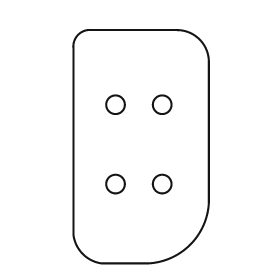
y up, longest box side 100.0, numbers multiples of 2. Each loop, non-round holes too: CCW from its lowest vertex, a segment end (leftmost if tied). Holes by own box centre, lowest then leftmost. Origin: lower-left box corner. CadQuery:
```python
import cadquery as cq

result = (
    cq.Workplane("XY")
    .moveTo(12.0, 0.0)
    .lineTo(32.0, 0.0)
    .threePointArc((50.0, 8.0), (58.0, 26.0))
    .lineTo(58.0, 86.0)
    .threePointArc((54.0, 96.0), (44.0, 100.0))
    .lineTo(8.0, 100.0)
    .threePointArc((2.0, 98.0), (0.0, 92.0))
    .lineTo(0.0, 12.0)
    .threePointArc((4.0, 4.0), (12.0, 0.0))
    .close()
    .moveTo(18.0, 34.0)
    .circle(4.0)
    .moveTo(38.0, 34.0)
    .circle(4.0)
    .moveTo(18.0, 68.0)
    .circle(4.0)
    .moveTo(38.0, 68.0)
    .circle(4.0)
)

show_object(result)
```